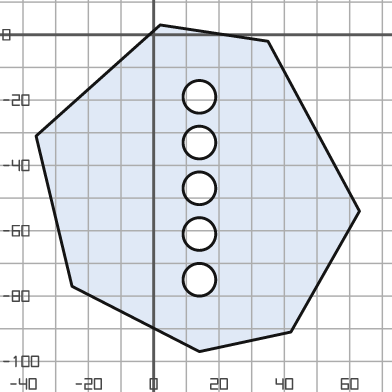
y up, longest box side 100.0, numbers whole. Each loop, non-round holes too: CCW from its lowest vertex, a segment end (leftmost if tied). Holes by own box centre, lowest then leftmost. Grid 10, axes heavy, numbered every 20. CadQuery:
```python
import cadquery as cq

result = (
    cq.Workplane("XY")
    .moveTo(14.0, -97.0)
    .lineTo(42.0, -91.0)
    .lineTo(63.0, -54.0)
    .lineTo(35.0, -2.0)
    .lineTo(2.0, 3.0)
    .lineTo(-36.0, -31.0)
    .lineTo(-25.0, -77.0)
    .close()
    .moveTo(14.0, -75.0)
    .circle(5.0)
    .moveTo(14.0, -61.0)
    .circle(5.0)
    .moveTo(14.0, -47.0)
    .circle(5.0)
    .moveTo(14.0, -33.0)
    .circle(5.0)
    .moveTo(14.0, -19.0)
    .circle(5.0)
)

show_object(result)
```